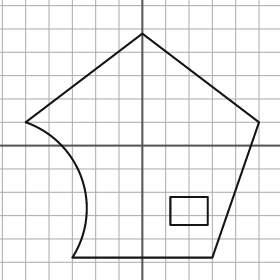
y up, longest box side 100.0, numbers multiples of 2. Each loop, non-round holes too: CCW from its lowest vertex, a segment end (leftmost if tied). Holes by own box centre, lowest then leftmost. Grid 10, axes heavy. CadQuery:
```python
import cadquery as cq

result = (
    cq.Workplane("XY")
    .moveTo(-30.0, -48.0)
    .lineTo(30.0, -48.0)
    .lineTo(50.0, 10.0)
    .lineTo(0.0, 48.0)
    .lineTo(-50.0, 10.0)
    .threePointArc((-26.0, -14.0), (-30.0, -48.0))
    .close()
    .moveTo(12.0, -34.0)
    .lineTo(28.0, -34.0)
    .lineTo(28.0, -22.0)
    .lineTo(12.0, -22.0)
    .close()
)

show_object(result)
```